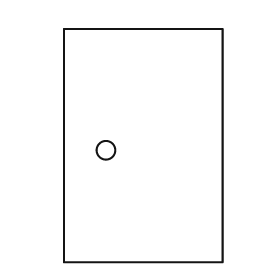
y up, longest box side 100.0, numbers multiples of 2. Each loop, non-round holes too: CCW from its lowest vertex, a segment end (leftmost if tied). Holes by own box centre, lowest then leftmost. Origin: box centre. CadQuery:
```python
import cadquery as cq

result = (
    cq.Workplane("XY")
    .moveTo(-34.0, -50.0)
    .lineTo(34.0, -50.0)
    .lineTo(34.0, 50.0)
    .lineTo(-34.0, 50.0)
    .close()
    .moveTo(-16.0, -2.0)
    .circle(4.0)
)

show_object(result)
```